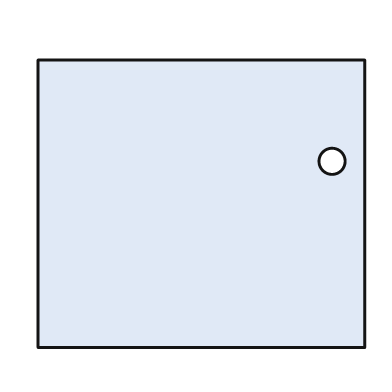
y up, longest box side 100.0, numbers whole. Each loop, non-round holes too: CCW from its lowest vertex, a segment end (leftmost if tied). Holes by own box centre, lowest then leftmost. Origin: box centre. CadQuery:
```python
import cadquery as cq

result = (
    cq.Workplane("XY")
    .moveTo(-50.0, -44.0)
    .lineTo(50.0, -44.0)
    .lineTo(50.0, 44.0)
    .lineTo(-50.0, 44.0)
    .close()
    .moveTo(40.0, 13.0)
    .circle(4.0)
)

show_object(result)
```